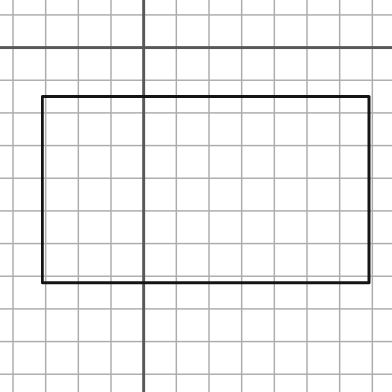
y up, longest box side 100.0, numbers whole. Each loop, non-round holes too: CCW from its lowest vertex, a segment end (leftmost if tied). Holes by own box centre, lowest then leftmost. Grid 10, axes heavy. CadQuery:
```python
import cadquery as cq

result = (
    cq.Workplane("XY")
    .moveTo(-31.0, -72.0)
    .lineTo(69.0, -72.0)
    .lineTo(69.0, -15.0)
    .lineTo(-31.0, -15.0)
    .close()
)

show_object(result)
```